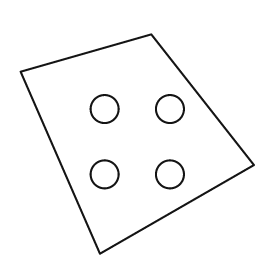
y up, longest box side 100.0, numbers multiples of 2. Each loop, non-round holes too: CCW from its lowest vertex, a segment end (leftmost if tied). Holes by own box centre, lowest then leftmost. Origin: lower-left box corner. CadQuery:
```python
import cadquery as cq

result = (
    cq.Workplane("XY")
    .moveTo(34.0, 0.0)
    .lineTo(100.0, 38.0)
    .lineTo(56.0, 94.0)
    .lineTo(0.0, 78.0)
    .close()
    .moveTo(36.0, 34.0)
    .circle(6.0)
    .moveTo(64.0, 34.0)
    .circle(6.0)
    .moveTo(36.0, 62.0)
    .circle(6.0)
    .moveTo(64.0, 62.0)
    .circle(6.0)
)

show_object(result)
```